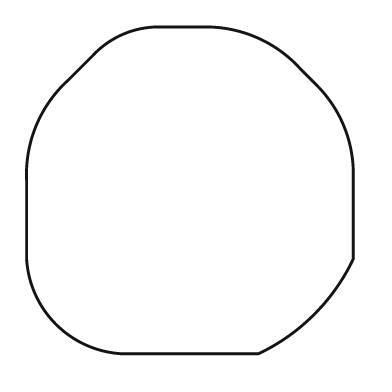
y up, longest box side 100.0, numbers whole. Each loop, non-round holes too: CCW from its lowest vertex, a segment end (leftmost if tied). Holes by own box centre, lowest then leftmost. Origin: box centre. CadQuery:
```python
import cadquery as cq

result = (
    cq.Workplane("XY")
    .moveTo(-21.0, -50.0)
    .lineTo(21.0, -50.0)
    .threePointArc((38.0, -38.0), (50.0, -21.0))
    .lineTo(50.0, 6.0)
    .threePointArc((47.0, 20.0), (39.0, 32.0))
    .lineTo(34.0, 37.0)
    .threePointArc((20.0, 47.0), (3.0, 50.0))
    .lineTo(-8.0, 50.0)
    .threePointArc((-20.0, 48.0), (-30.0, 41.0))
    .lineTo(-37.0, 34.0)
    .threePointArc((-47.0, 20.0), (-50.0, 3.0))
    .lineTo(-50.0, -21.0)
    .threePointArc((-41.0, -41.0), (-21.0, -50.0))
    .close()
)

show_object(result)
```